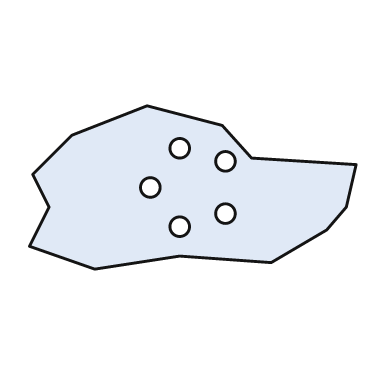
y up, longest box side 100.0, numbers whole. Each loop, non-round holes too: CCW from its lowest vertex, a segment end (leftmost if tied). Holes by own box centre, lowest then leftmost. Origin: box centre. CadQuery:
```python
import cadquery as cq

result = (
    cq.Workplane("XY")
    .moveTo(-30.0, -25.0)
    .lineTo(-4.0, -21.0)
    .lineTo(24.0, -23.0)
    .lineTo(41.0, -13.0)
    .lineTo(47.0, -6.0)
    .lineTo(50.0, 7.0)
    .lineTo(18.0, 9.0)
    .lineTo(9.0, 19.0)
    .lineTo(-14.0, 25.0)
    .lineTo(-37.0, 16.0)
    .lineTo(-49.0, 4.0)
    .lineTo(-44.0, -6.0)
    .lineTo(-50.0, -18.0)
    .close()
    .moveTo(-4.0, -12.0)
    .circle(3.0)
    .moveTo(10.0, -8.0)
    .circle(3.0)
    .moveTo(-13.0, 0.0)
    .circle(3.0)
    .moveTo(10.0, 8.0)
    .circle(3.0)
    .moveTo(-4.0, 12.0)
    .circle(3.0)
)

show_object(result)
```